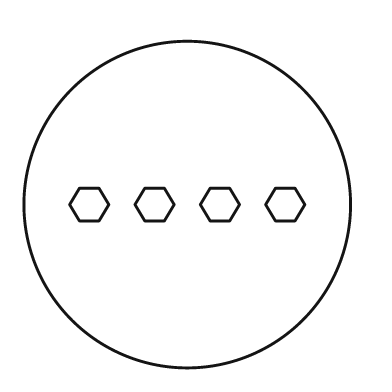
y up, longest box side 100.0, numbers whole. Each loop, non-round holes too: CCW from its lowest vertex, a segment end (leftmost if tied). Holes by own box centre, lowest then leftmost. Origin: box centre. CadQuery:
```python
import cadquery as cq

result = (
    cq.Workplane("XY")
    .moveTo(0.0, 0.0)
    .circle(50.0)
    .moveTo(-33.0, -5.0)
    .lineTo(-27.0, -5.0)
    .lineTo(-24.0, 0.0)
    .lineTo(-27.0, 5.0)
    .lineTo(-33.0, 5.0)
    .lineTo(-36.0, 0.0)
    .close()
    .moveTo(-13.0, -5.0)
    .lineTo(-7.0, -5.0)
    .lineTo(-4.0, 0.0)
    .lineTo(-7.0, 5.0)
    .lineTo(-13.0, 5.0)
    .lineTo(-16.0, 0.0)
    .close()
    .moveTo(7.0, -5.0)
    .lineTo(13.0, -5.0)
    .lineTo(16.0, 0.0)
    .lineTo(13.0, 5.0)
    .lineTo(7.0, 5.0)
    .lineTo(4.0, 0.0)
    .close()
    .moveTo(27.0, -5.0)
    .lineTo(33.0, -5.0)
    .lineTo(36.0, 0.0)
    .lineTo(33.0, 5.0)
    .lineTo(27.0, 5.0)
    .lineTo(24.0, 0.0)
    .close()
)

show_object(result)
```